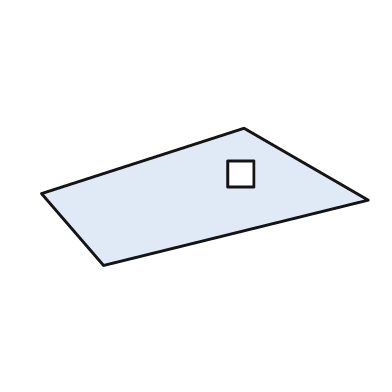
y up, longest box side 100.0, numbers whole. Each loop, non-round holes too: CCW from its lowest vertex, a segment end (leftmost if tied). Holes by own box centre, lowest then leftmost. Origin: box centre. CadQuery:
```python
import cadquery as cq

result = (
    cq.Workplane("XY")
    .moveTo(-31.0, -21.0)
    .lineTo(50.0, -1.0)
    .lineTo(12.0, 21.0)
    .lineTo(-50.0, 1.0)
    .close()
    .moveTo(7.0, 3.0)
    .lineTo(15.0, 3.0)
    .lineTo(15.0, 11.0)
    .lineTo(7.0, 11.0)
    .close()
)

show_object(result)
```